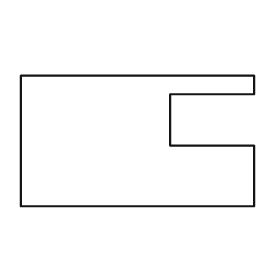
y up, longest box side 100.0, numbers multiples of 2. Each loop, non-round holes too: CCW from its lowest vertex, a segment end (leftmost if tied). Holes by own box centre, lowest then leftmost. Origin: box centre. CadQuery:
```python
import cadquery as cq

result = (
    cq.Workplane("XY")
    .moveTo(-50.0, -28.0)
    .lineTo(50.0, -28.0)
    .lineTo(50.0, -2.0)
    .lineTo(14.0, -2.0)
    .lineTo(14.0, 20.0)
    .lineTo(50.0, 20.0)
    .lineTo(50.0, 28.0)
    .lineTo(-50.0, 28.0)
    .close()
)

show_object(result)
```